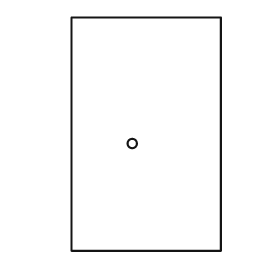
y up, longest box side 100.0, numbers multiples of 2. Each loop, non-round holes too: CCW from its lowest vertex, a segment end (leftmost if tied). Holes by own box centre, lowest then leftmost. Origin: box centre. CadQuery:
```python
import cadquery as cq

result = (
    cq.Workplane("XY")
    .moveTo(-32.0, -50.0)
    .lineTo(32.0, -50.0)
    .lineTo(32.0, 50.0)
    .lineTo(-32.0, 50.0)
    .close()
    .moveTo(-6.0, -4.0)
    .circle(2.0)
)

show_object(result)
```